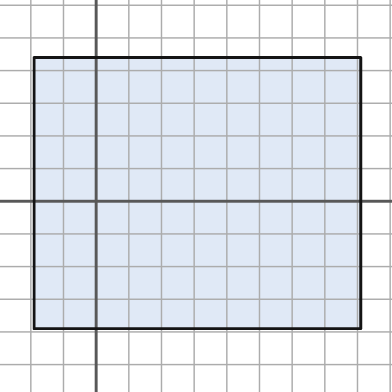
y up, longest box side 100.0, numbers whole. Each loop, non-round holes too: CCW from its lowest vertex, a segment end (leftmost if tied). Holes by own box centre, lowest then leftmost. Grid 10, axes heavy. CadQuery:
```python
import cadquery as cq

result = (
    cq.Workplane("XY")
    .moveTo(-19.0, -39.0)
    .lineTo(81.0, -39.0)
    .lineTo(81.0, 44.0)
    .lineTo(-19.0, 44.0)
    .close()
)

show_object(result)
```